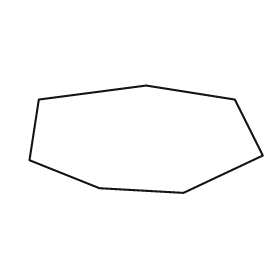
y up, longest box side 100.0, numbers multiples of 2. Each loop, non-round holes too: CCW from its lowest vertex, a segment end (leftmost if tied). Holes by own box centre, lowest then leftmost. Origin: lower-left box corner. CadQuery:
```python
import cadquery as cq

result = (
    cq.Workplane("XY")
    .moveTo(66.0, 0.0)
    .lineTo(100.0, 16.0)
    .lineTo(88.0, 40.0)
    .lineTo(50.0, 46.0)
    .lineTo(4.0, 40.0)
    .lineTo(0.0, 14.0)
    .lineTo(30.0, 2.0)
    .close()
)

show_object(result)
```